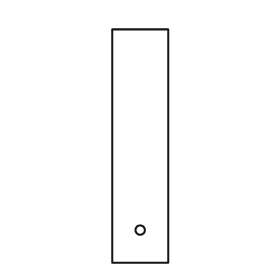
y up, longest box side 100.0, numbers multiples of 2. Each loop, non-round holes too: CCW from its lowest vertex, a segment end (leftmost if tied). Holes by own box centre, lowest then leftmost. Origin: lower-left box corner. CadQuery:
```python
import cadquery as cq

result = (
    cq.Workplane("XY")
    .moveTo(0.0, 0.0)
    .lineTo(24.0, 0.0)
    .lineTo(24.0, 100.0)
    .lineTo(0.0, 100.0)
    .close()
    .moveTo(12.0, 14.0)
    .circle(2.0)
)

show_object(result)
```